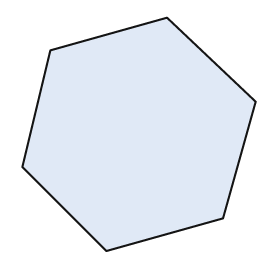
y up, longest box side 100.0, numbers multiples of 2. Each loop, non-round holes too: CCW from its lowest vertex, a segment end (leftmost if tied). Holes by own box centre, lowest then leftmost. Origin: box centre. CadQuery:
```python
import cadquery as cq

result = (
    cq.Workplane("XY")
    .moveTo(-14.0, -50.0)
    .lineTo(36.0, -36.0)
    .lineTo(50.0, 14.0)
    .lineTo(12.0, 50.0)
    .lineTo(-38.0, 36.0)
    .lineTo(-50.0, -14.0)
    .close()
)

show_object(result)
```